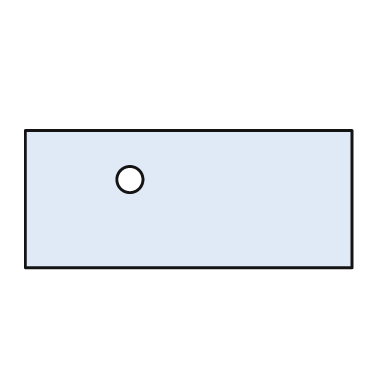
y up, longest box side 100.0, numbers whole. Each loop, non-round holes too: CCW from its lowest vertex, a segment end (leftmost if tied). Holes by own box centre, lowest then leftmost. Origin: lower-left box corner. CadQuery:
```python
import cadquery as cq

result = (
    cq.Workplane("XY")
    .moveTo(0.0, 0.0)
    .lineTo(100.0, 0.0)
    .lineTo(100.0, 42.0)
    .lineTo(0.0, 42.0)
    .close()
    .moveTo(32.0, 27.0)
    .circle(4.0)
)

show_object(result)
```